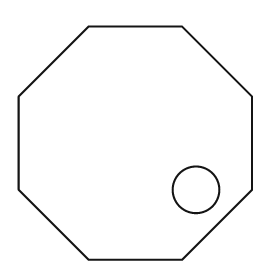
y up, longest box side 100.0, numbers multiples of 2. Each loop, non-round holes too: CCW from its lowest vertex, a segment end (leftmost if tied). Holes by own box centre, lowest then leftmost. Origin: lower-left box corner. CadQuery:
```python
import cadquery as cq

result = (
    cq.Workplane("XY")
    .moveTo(30.0, 0.0)
    .lineTo(70.0, 0.0)
    .lineTo(100.0, 30.0)
    .lineTo(100.0, 70.0)
    .lineTo(70.0, 100.0)
    .lineTo(30.0, 100.0)
    .lineTo(0.0, 70.0)
    .lineTo(0.0, 30.0)
    .close()
    .moveTo(76.0, 30.0)
    .circle(10.0)
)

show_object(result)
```